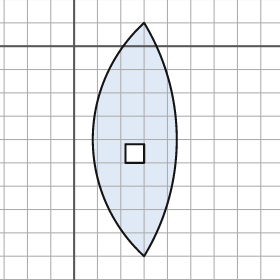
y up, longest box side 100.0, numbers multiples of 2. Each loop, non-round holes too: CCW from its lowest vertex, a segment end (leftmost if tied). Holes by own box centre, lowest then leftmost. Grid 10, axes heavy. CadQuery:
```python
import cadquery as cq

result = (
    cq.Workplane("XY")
    .moveTo(30.0, -90.0)
    .threePointArc((44.0, -40.0), (30.0, 10.0))
    .threePointArc((8.0, -40.0), (30.0, -90.0))
    .close()
    .moveTo(22.0, -50.0)
    .lineTo(30.0, -50.0)
    .lineTo(30.0, -42.0)
    .lineTo(22.0, -42.0)
    .close()
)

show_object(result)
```